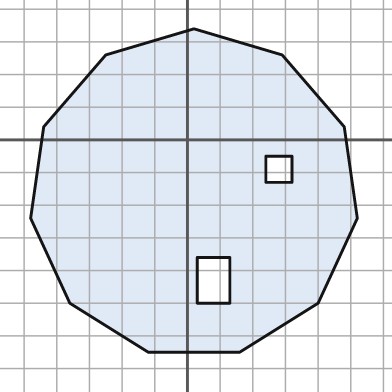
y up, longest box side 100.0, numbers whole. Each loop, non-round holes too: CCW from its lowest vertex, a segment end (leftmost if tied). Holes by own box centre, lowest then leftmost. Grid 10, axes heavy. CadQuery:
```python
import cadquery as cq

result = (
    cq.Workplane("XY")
    .moveTo(-12.0, -65.0)
    .lineTo(16.0, -65.0)
    .lineTo(40.0, -50.0)
    .lineTo(52.0, -24.0)
    .lineTo(48.0, 4.0)
    .lineTo(29.0, 26.0)
    .lineTo(2.0, 34.0)
    .lineTo(-25.0, 26.0)
    .lineTo(-44.0, 4.0)
    .lineTo(-48.0, -24.0)
    .lineTo(-36.0, -50.0)
    .close()
    .moveTo(3.0, -50.0)
    .lineTo(13.0, -50.0)
    .lineTo(13.0, -36.0)
    .lineTo(3.0, -36.0)
    .close()
    .moveTo(24.0, -13.0)
    .lineTo(32.0, -13.0)
    .lineTo(32.0, -5.0)
    .lineTo(24.0, -5.0)
    .close()
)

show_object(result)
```